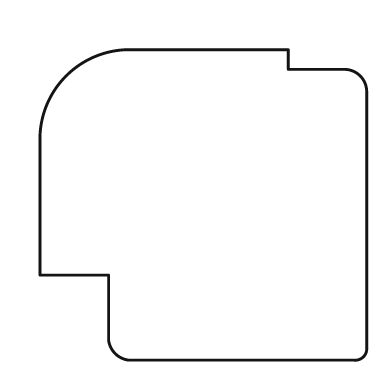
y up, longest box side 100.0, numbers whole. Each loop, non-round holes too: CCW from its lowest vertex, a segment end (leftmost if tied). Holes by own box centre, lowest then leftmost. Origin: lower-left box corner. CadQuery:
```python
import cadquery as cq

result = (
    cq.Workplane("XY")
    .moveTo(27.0, 0.0)
    .lineTo(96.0, 0.0)
    .threePointArc((99.0, 1.0), (100.0, 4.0))
    .lineTo(100.0, 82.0)
    .threePointArc((98.0, 87.0), (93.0, 89.0))
    .lineTo(76.0, 89.0)
    .lineTo(76.0, 95.0)
    .lineTo(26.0, 95.0)
    .threePointArc((8.0, 87.0), (0.0, 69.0))
    .lineTo(0.0, 26.0)
    .lineTo(21.0, 26.0)
    .lineTo(21.0, 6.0)
    .threePointArc((23.0, 2.0), (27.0, 0.0))
    .close()
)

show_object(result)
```